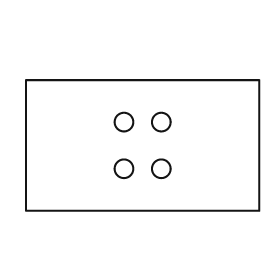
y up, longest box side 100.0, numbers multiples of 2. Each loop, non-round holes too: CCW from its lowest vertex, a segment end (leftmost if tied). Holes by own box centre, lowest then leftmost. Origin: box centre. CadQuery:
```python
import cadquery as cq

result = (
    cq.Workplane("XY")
    .moveTo(-50.0, -28.0)
    .lineTo(50.0, -28.0)
    .lineTo(50.0, 28.0)
    .lineTo(-50.0, 28.0)
    .close()
    .moveTo(-8.0, -10.0)
    .circle(4.0)
    .moveTo(8.0, -10.0)
    .circle(4.0)
    .moveTo(-8.0, 10.0)
    .circle(4.0)
    .moveTo(8.0, 10.0)
    .circle(4.0)
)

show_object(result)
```